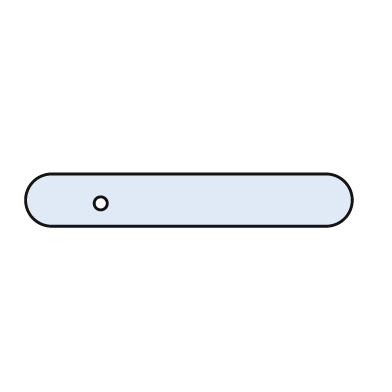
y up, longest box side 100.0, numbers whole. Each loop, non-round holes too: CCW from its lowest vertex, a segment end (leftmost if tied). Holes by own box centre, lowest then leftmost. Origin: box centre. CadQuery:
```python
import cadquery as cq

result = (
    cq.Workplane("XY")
    .moveTo(-42.0, -8.0)
    .lineTo(42.0, -8.0)
    .threePointArc((50.0, 0.0), (42.0, 8.0))
    .lineTo(-42.0, 8.0)
    .threePointArc((-50.0, 0.0), (-42.0, -8.0))
    .close()
    .moveTo(-27.0, -1.0)
    .circle(2.0)
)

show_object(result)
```